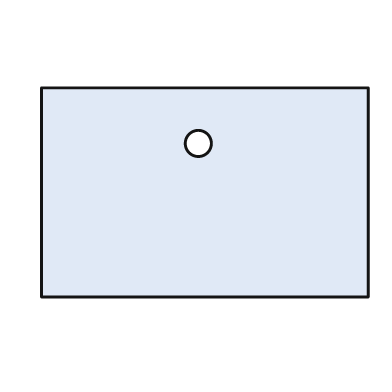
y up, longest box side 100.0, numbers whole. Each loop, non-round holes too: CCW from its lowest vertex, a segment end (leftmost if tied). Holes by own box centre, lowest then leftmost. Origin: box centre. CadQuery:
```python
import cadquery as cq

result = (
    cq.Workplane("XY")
    .moveTo(-50.0, -32.0)
    .lineTo(50.0, -32.0)
    .lineTo(50.0, 32.0)
    .lineTo(-50.0, 32.0)
    .close()
    .moveTo(-2.0, 15.0)
    .circle(4.0)
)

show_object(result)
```